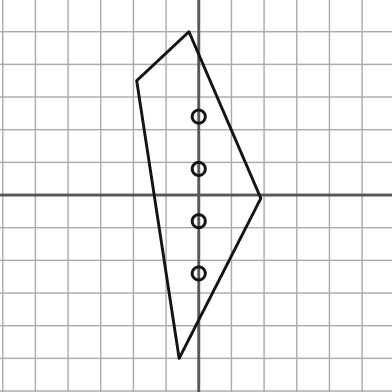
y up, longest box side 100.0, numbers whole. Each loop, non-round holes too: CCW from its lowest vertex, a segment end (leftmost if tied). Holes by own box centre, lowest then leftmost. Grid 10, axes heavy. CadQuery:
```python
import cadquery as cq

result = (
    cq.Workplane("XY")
    .moveTo(-6.0, -50.0)
    .lineTo(19.0, -1.0)
    .lineTo(-3.0, 50.0)
    .lineTo(-19.0, 35.0)
    .close()
    .moveTo(0.0, -24.0)
    .circle(2.0)
    .moveTo(0.0, -8.0)
    .circle(2.0)
    .moveTo(0.0, 8.0)
    .circle(2.0)
    .moveTo(0.0, 24.0)
    .circle(2.0)
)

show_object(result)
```